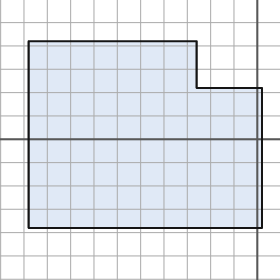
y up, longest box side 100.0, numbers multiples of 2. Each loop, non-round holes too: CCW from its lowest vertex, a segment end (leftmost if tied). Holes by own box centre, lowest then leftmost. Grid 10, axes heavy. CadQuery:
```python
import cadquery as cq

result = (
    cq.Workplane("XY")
    .moveTo(-98.0, -38.0)
    .lineTo(2.0, -38.0)
    .lineTo(2.0, 22.0)
    .lineTo(-26.0, 22.0)
    .lineTo(-26.0, 42.0)
    .lineTo(-98.0, 42.0)
    .close()
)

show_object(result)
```